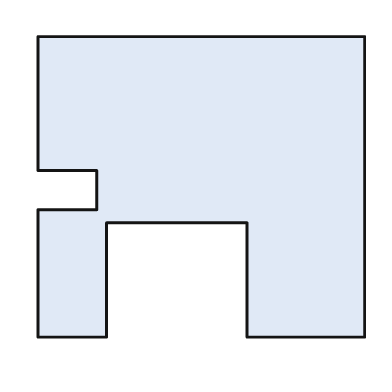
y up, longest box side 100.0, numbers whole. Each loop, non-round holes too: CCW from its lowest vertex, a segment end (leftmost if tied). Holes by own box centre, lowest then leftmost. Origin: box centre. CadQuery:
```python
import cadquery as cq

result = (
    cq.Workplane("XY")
    .moveTo(-50.0, -46.0)
    .lineTo(-29.0, -46.0)
    .lineTo(-29.0, -11.0)
    .lineTo(14.0, -11.0)
    .lineTo(14.0, -46.0)
    .lineTo(50.0, -46.0)
    .lineTo(50.0, 46.0)
    .lineTo(-50.0, 46.0)
    .lineTo(-50.0, 5.0)
    .lineTo(-32.0, 5.0)
    .lineTo(-32.0, -7.0)
    .lineTo(-50.0, -7.0)
    .close()
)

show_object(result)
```